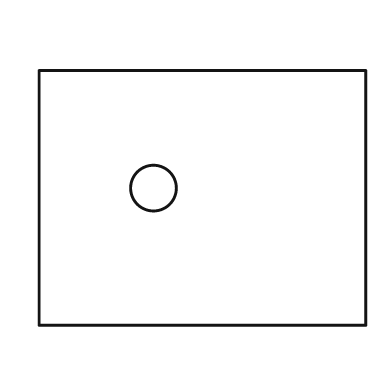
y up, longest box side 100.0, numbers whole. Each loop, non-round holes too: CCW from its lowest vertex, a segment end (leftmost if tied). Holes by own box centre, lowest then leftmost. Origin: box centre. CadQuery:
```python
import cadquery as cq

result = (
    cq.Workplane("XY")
    .moveTo(-50.0, -39.0)
    .lineTo(50.0, -39.0)
    .lineTo(50.0, 39.0)
    .lineTo(-50.0, 39.0)
    .close()
    .moveTo(-15.0, 3.0)
    .circle(7.0)
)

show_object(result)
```